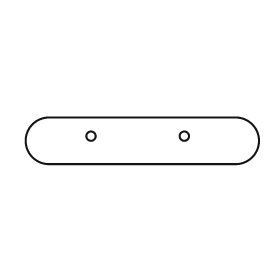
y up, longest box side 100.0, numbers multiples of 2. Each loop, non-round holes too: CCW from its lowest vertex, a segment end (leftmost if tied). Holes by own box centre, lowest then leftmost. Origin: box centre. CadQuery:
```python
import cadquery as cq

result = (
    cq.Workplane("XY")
    .moveTo(-40.0, -10.0)
    .lineTo(40.0, -10.0)
    .threePointArc((50.0, 0.0), (40.0, 10.0))
    .lineTo(-40.0, 10.0)
    .threePointArc((-50.0, 0.0), (-40.0, -10.0))
    .close()
    .moveTo(-22.0, 2.0)
    .circle(2.0)
    .moveTo(18.0, 2.0)
    .circle(2.0)
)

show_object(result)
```